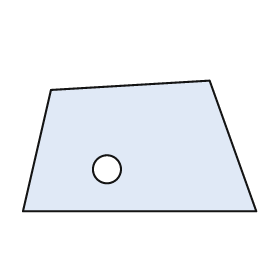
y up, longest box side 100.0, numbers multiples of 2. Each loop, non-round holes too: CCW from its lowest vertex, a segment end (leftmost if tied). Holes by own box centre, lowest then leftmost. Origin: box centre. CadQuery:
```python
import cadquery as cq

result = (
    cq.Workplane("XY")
    .moveTo(-50.0, -28.0)
    .lineTo(50.0, -28.0)
    .lineTo(30.0, 28.0)
    .lineTo(-38.0, 24.0)
    .close()
    .moveTo(-14.0, -10.0)
    .circle(6.0)
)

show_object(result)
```